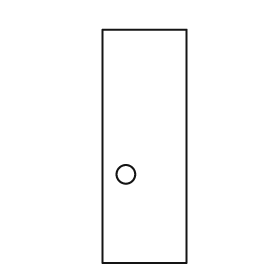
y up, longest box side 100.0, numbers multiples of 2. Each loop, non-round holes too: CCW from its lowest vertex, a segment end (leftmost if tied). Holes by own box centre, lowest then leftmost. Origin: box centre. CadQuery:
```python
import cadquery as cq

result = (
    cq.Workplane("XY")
    .moveTo(-18.0, -50.0)
    .lineTo(18.0, -50.0)
    .lineTo(18.0, 50.0)
    .lineTo(-18.0, 50.0)
    .close()
    .moveTo(-8.0, -12.0)
    .circle(4.0)
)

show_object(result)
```